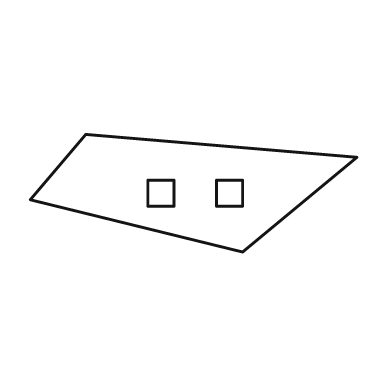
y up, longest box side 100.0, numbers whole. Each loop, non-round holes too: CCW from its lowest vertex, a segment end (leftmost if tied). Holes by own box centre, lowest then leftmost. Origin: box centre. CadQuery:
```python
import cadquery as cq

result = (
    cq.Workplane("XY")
    .moveTo(15.0, -18.0)
    .lineTo(50.0, 11.0)
    .lineTo(-33.0, 18.0)
    .lineTo(-50.0, -2.0)
    .close()
    .moveTo(-14.0, -4.0)
    .lineTo(-6.0, -4.0)
    .lineTo(-6.0, 4.0)
    .lineTo(-14.0, 4.0)
    .close()
    .moveTo(7.0, -4.0)
    .lineTo(15.0, -4.0)
    .lineTo(15.0, 4.0)
    .lineTo(7.0, 4.0)
    .close()
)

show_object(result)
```